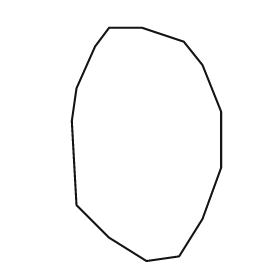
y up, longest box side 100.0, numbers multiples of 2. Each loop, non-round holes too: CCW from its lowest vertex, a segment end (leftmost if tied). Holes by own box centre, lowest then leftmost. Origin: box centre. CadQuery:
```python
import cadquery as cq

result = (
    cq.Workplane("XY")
    .moveTo(0.0, -50.0)
    .lineTo(14.0, -48.0)
    .lineTo(24.0, -32.0)
    .lineTo(32.0, -10.0)
    .lineTo(32.0, 14.0)
    .lineTo(24.0, 34.0)
    .lineTo(16.0, 44.0)
    .lineTo(-2.0, 50.0)
    .lineTo(-16.0, 50.0)
    .lineTo(-22.0, 42.0)
    .lineTo(-30.0, 24.0)
    .lineTo(-32.0, 10.0)
    .lineTo(-30.0, -26.0)
    .lineTo(-16.0, -40.0)
    .close()
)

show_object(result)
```